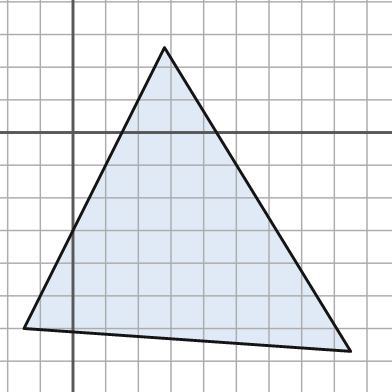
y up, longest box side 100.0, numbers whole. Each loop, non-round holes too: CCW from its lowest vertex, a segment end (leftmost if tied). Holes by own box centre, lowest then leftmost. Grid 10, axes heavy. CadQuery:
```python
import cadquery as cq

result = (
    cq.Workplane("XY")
    .moveTo(85.0, -67.0)
    .lineTo(28.0, 26.0)
    .lineTo(-15.0, -60.0)
    .close()
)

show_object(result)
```